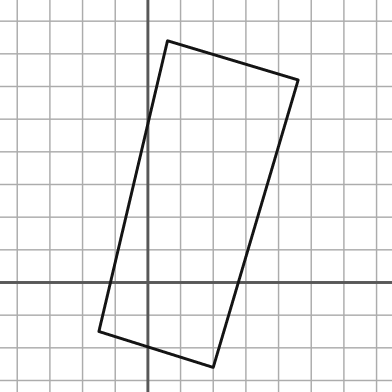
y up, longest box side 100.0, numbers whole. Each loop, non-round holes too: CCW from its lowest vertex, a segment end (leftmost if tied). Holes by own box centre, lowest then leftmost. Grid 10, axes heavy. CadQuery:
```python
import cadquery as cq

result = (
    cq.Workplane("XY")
    .moveTo(20.0, -26.0)
    .lineTo(46.0, 62.0)
    .lineTo(6.0, 74.0)
    .lineTo(-15.0, -15.0)
    .close()
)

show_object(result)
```